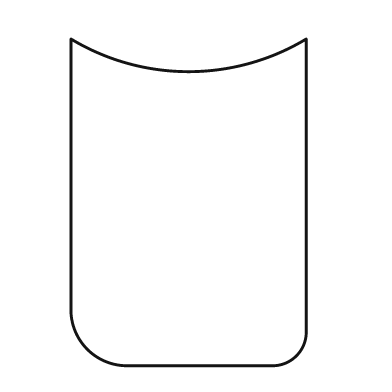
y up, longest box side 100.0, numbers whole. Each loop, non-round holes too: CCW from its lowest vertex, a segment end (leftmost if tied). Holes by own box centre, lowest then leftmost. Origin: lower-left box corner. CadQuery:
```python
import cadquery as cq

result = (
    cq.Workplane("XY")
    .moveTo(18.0, 0.0)
    .lineTo(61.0, 0.0)
    .threePointArc((69.0, 3.0), (72.0, 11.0))
    .lineTo(72.0, 100.0)
    .threePointArc((36.0, 90.0), (0.0, 100.0))
    .lineTo(0.0, 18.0)
    .threePointArc((5.0, 5.0), (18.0, 0.0))
    .close()
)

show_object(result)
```